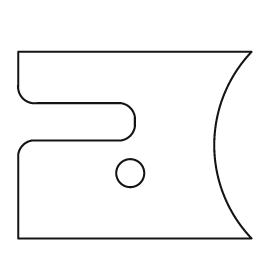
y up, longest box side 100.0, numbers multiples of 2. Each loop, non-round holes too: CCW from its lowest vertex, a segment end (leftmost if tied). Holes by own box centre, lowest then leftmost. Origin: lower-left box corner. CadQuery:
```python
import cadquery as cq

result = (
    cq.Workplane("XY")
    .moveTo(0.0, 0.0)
    .lineTo(100.0, 0.0)
    .threePointArc((84.0, 40.0), (100.0, 80.0))
    .lineTo(0.0, 80.0)
    .lineTo(0.0, 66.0)
    .threePointArc((2.0, 60.0), (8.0, 58.0))
    .lineTo(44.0, 58.0)
    .threePointArc((48.0, 56.0), (50.0, 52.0))
    .lineTo(50.0, 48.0)
    .threePointArc((48.0, 44.0), (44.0, 42.0))
    .lineTo(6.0, 42.0)
    .threePointArc((2.0, 40.0), (0.0, 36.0))
    .close()
    .moveTo(48.0, 28.0)
    .circle(6.0)
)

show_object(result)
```